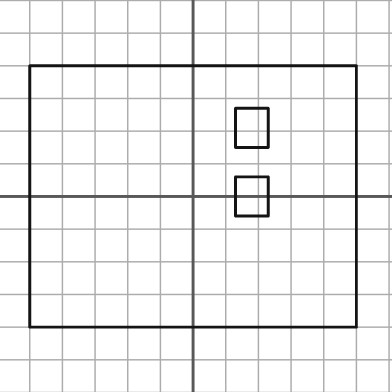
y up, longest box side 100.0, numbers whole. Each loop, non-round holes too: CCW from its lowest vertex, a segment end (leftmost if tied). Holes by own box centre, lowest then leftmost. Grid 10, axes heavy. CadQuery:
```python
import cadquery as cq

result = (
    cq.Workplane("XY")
    .moveTo(-50.0, -40.0)
    .lineTo(50.0, -40.0)
    .lineTo(50.0, 40.0)
    .lineTo(-50.0, 40.0)
    .close()
    .moveTo(13.0, -6.0)
    .lineTo(23.0, -6.0)
    .lineTo(23.0, 6.0)
    .lineTo(13.0, 6.0)
    .close()
    .moveTo(13.0, 15.0)
    .lineTo(23.0, 15.0)
    .lineTo(23.0, 27.0)
    .lineTo(13.0, 27.0)
    .close()
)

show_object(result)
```